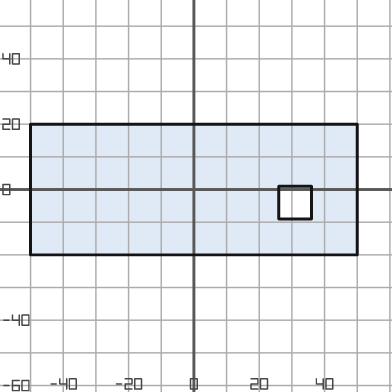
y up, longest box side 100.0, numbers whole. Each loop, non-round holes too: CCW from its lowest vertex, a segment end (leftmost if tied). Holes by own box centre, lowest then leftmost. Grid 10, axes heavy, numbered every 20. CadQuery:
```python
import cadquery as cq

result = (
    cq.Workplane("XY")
    .moveTo(-50.0, -20.0)
    .lineTo(50.0, -20.0)
    .lineTo(50.0, 20.0)
    .lineTo(-50.0, 20.0)
    .close()
    .moveTo(26.0, -9.0)
    .lineTo(36.0, -9.0)
    .lineTo(36.0, 1.0)
    .lineTo(26.0, 1.0)
    .close()
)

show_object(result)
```